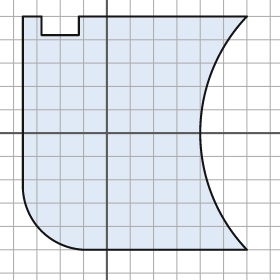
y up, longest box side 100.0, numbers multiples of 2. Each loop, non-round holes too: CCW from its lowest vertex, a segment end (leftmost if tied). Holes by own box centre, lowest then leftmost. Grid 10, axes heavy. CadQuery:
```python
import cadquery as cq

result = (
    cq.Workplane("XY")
    .moveTo(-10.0, -50.0)
    .lineTo(60.0, -50.0)
    .threePointArc((40.0, 0.0), (60.0, 50.0))
    .lineTo(-12.0, 50.0)
    .lineTo(-12.0, 42.0)
    .lineTo(-28.0, 42.0)
    .lineTo(-28.0, 50.0)
    .lineTo(-36.0, 50.0)
    .lineTo(-36.0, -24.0)
    .threePointArc((-28.0, -42.0), (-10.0, -50.0))
    .close()
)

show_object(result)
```